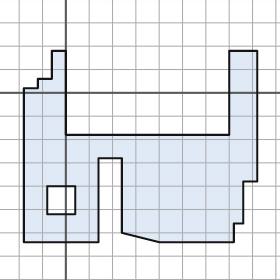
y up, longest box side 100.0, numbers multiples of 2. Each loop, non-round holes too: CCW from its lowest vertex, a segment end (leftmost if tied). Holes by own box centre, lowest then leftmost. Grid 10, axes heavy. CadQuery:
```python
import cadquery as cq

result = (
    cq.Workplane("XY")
    .moveTo(-18.0, -64.0)
    .lineTo(14.0, -64.0)
    .lineTo(14.0, -28.0)
    .lineTo(24.0, -28.0)
    .lineTo(24.0, -60.0)
    .lineTo(40.0, -64.0)
    .lineTo(72.0, -64.0)
    .lineTo(72.0, -56.0)
    .lineTo(76.0, -56.0)
    .lineTo(76.0, -38.0)
    .lineTo(82.0, -38.0)
    .lineTo(82.0, 18.0)
    .lineTo(70.0, 18.0)
    .lineTo(70.0, -18.0)
    .lineTo(0.0, -18.0)
    .lineTo(0.0, 18.0)
    .lineTo(-6.0, 18.0)
    .lineTo(-6.0, 6.0)
    .lineTo(-12.0, 6.0)
    .lineTo(-12.0, 2.0)
    .lineTo(-18.0, 2.0)
    .close()
    .moveTo(-8.0, -52.0)
    .lineTo(4.0, -52.0)
    .lineTo(4.0, -40.0)
    .lineTo(-8.0, -40.0)
    .close()
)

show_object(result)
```